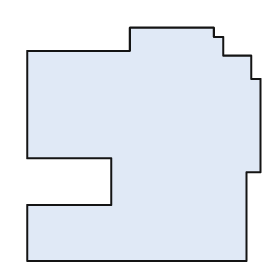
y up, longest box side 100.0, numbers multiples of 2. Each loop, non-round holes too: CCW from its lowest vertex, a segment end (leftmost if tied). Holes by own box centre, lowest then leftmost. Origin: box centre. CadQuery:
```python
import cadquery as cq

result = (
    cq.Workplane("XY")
    .moveTo(-50.0, -50.0)
    .lineTo(44.0, -50.0)
    .lineTo(44.0, -12.0)
    .lineTo(50.0, -12.0)
    .lineTo(50.0, 28.0)
    .lineTo(46.0, 28.0)
    .lineTo(46.0, 38.0)
    .lineTo(34.0, 38.0)
    .lineTo(34.0, 46.0)
    .lineTo(30.0, 46.0)
    .lineTo(30.0, 50.0)
    .lineTo(-6.0, 50.0)
    .lineTo(-6.0, 40.0)
    .lineTo(-50.0, 40.0)
    .lineTo(-50.0, -6.0)
    .lineTo(-14.0, -6.0)
    .lineTo(-14.0, -26.0)
    .lineTo(-50.0, -26.0)
    .close()
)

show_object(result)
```